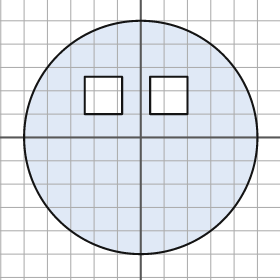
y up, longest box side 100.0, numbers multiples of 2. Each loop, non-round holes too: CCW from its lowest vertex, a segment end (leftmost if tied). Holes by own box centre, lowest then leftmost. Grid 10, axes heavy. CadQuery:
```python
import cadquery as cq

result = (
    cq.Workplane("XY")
    .moveTo(0.0, 0.0)
    .circle(50.0)
    .moveTo(-24.0, 10.0)
    .lineTo(-8.0, 10.0)
    .lineTo(-8.0, 26.0)
    .lineTo(-24.0, 26.0)
    .close()
    .moveTo(4.0, 10.0)
    .lineTo(20.0, 10.0)
    .lineTo(20.0, 26.0)
    .lineTo(4.0, 26.0)
    .close()
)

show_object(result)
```